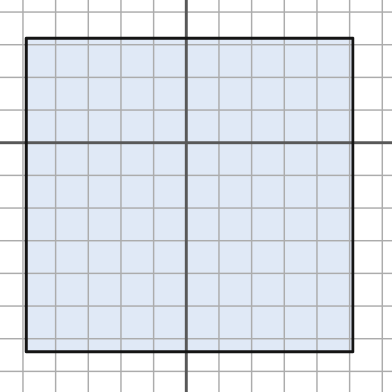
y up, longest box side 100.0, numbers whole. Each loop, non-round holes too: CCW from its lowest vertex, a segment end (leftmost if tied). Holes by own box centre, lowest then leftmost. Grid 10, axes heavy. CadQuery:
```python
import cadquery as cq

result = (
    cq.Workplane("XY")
    .moveTo(-49.0, -64.0)
    .lineTo(51.0, -64.0)
    .lineTo(51.0, 32.0)
    .lineTo(-49.0, 32.0)
    .close()
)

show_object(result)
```